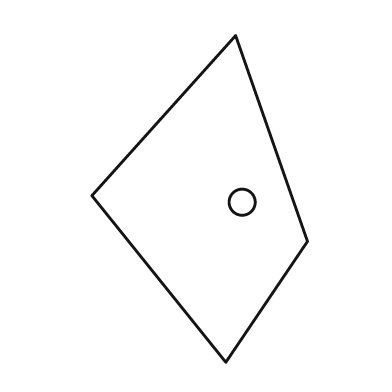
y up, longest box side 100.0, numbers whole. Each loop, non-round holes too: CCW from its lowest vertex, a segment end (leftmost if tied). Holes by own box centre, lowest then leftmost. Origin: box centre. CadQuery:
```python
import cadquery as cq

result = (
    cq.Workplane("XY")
    .moveTo(8.0, -50.0)
    .lineTo(33.0, -13.0)
    .lineTo(11.0, 50.0)
    .lineTo(-33.0, 1.0)
    .close()
    .moveTo(13.0, -1.0)
    .circle(4.0)
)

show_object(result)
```